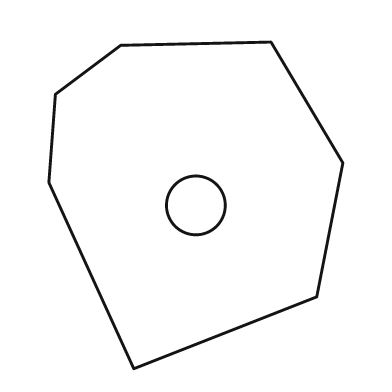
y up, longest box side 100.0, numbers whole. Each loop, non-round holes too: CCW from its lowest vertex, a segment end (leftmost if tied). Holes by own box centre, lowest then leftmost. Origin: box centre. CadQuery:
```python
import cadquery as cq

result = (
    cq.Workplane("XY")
    .moveTo(-19.0, -50.0)
    .lineTo(37.0, -28.0)
    .lineTo(45.0, 13.0)
    .lineTo(23.0, 50.0)
    .lineTo(-23.0, 49.0)
    .lineTo(-43.0, 34.0)
    .lineTo(-45.0, 7.0)
    .close()
    .moveTo(0.0, 0.0)
    .circle(9.0)
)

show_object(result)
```